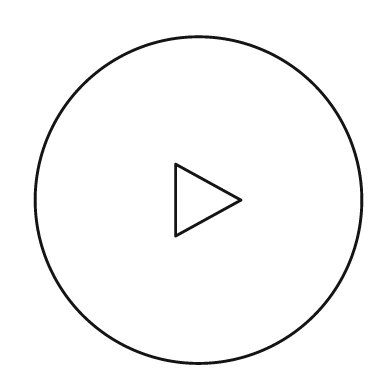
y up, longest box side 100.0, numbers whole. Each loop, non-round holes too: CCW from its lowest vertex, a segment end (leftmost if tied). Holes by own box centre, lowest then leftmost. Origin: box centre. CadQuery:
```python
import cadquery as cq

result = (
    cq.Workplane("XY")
    .moveTo(0.0, 0.0)
    .circle(50.0)
    .moveTo(-7.0, -11.0)
    .lineTo(13.0, 0.0)
    .lineTo(-7.0, 11.0)
    .close()
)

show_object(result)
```